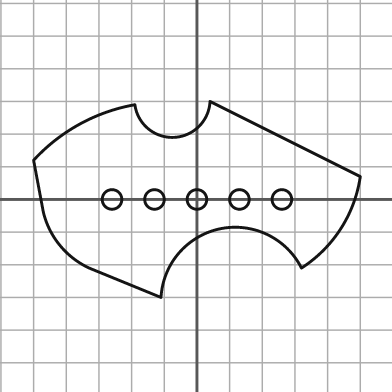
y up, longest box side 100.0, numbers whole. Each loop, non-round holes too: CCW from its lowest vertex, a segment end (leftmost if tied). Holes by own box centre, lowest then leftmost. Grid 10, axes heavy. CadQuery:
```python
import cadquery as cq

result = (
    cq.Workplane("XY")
    .moveTo(-11.0, -30.0)
    .threePointArc((7.0, -9.0), (32.0, -21.0))
    .threePointArc((44.0, -9.0), (50.0, 7.0))
    .lineTo(4.0, 30.0)
    .threePointArc((-7.0, 19.0), (-19.0, 29.0))
    .threePointArc((-36.0, 23.0), (-50.0, 12.0))
    .lineTo(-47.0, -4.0)
    .threePointArc((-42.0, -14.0), (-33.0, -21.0))
    .close()
    .moveTo(-26.0, 0.0)
    .circle(3.0)
    .moveTo(-13.0, 0.0)
    .circle(3.0)
    .moveTo(0.0, 0.0)
    .circle(3.0)
    .moveTo(13.0, 0.0)
    .circle(3.0)
    .moveTo(26.0, 0.0)
    .circle(3.0)
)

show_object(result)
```